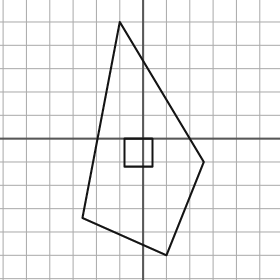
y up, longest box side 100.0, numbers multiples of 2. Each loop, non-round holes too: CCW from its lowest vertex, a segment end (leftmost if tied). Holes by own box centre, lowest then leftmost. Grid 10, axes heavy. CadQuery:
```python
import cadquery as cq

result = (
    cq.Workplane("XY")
    .moveTo(10.0, -50.0)
    .lineTo(26.0, -10.0)
    .lineTo(-10.0, 50.0)
    .lineTo(-26.0, -34.0)
    .close()
    .moveTo(-8.0, -12.0)
    .lineTo(4.0, -12.0)
    .lineTo(4.0, 0.0)
    .lineTo(-8.0, 0.0)
    .close()
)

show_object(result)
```